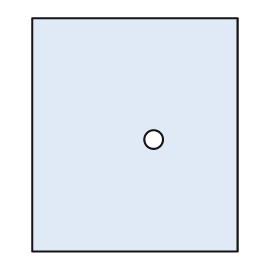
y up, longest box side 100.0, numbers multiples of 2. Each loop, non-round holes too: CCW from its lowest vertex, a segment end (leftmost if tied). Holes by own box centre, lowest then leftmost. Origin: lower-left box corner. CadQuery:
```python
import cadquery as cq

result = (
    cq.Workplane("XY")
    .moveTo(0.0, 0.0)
    .lineTo(88.0, 0.0)
    .lineTo(88.0, 100.0)
    .lineTo(0.0, 100.0)
    .close()
    .moveTo(52.0, 48.0)
    .circle(4.0)
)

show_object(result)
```